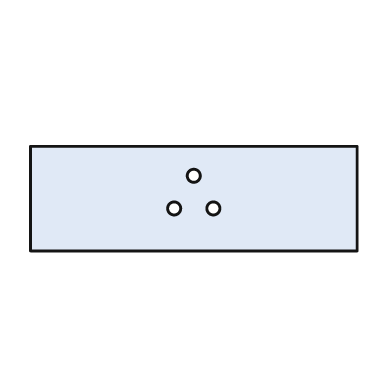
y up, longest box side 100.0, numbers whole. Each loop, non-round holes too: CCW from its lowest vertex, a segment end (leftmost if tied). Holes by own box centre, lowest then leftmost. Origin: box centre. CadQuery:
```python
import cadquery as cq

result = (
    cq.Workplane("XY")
    .moveTo(-50.0, -16.0)
    .lineTo(50.0, -16.0)
    .lineTo(50.0, 16.0)
    .lineTo(-50.0, 16.0)
    .close()
    .moveTo(-6.0, -3.0)
    .circle(2.0)
    .moveTo(6.0, -3.0)
    .circle(2.0)
    .moveTo(0.0, 7.0)
    .circle(2.0)
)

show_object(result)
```